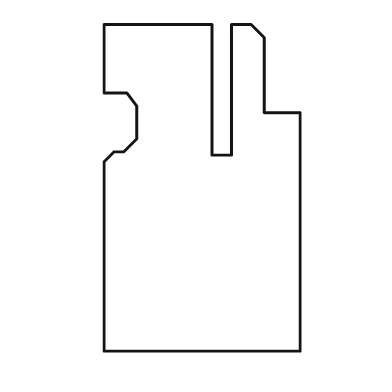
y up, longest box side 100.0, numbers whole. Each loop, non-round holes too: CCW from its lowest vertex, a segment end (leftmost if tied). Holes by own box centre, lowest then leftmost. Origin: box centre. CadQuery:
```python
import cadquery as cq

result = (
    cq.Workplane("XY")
    .moveTo(-30.0, -50.0)
    .lineTo(30.0, -50.0)
    .lineTo(30.0, 23.0)
    .lineTo(19.0, 23.0)
    .lineTo(19.0, 46.0)
    .lineTo(15.0, 50.0)
    .lineTo(9.0, 50.0)
    .lineTo(9.0, 10.0)
    .lineTo(3.0, 10.0)
    .lineTo(3.0, 50.0)
    .lineTo(-30.0, 50.0)
    .lineTo(-30.0, 29.0)
    .lineTo(-23.0, 29.0)
    .lineTo(-20.0, 25.0)
    .lineTo(-20.0, 15.0)
    .lineTo(-24.0, 11.0)
    .lineTo(-27.0, 11.0)
    .lineTo(-30.0, 8.0)
    .close()
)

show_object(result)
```